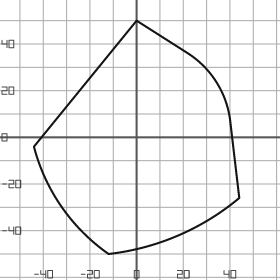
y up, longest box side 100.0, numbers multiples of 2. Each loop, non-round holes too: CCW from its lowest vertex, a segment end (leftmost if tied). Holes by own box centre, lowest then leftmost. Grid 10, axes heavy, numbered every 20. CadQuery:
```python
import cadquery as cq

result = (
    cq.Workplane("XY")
    .moveTo(-12.0, -50.0)
    .threePointArc((18.0, -42.0), (44.0, -26.0))
    .lineTo(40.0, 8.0)
    .threePointArc((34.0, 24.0), (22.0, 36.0))
    .lineTo(0.0, 50.0)
    .lineTo(-44.0, -4.0)
    .threePointArc((-32.0, -30.0), (-12.0, -50.0))
    .close()
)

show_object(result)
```